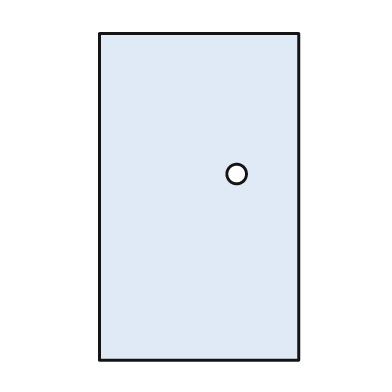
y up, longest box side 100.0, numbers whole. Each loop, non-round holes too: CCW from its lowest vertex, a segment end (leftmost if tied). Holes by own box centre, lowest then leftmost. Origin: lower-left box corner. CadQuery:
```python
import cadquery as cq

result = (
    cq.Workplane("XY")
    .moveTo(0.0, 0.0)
    .lineTo(61.0, 0.0)
    .lineTo(61.0, 100.0)
    .lineTo(0.0, 100.0)
    .close()
    .moveTo(42.0, 57.0)
    .circle(3.0)
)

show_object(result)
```